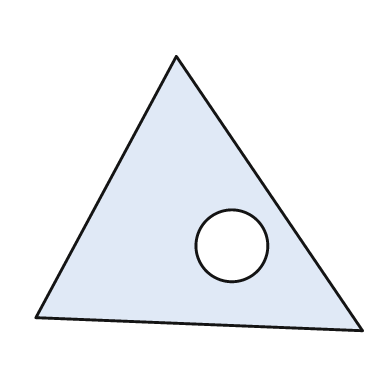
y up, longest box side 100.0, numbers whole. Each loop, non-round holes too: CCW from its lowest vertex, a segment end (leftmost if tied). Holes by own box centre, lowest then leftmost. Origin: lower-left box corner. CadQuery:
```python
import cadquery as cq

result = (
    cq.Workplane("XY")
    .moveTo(100.0, 0.0)
    .lineTo(43.0, 84.0)
    .lineTo(0.0, 4.0)
    .close()
    .moveTo(60.0, 26.0)
    .circle(11.0)
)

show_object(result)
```